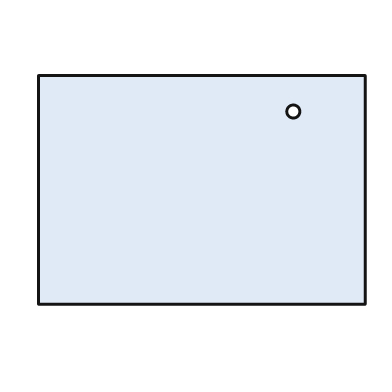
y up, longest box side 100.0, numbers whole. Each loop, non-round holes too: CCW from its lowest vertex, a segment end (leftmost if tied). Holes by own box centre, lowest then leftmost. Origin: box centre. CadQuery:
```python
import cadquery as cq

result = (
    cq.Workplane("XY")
    .moveTo(-50.0, -35.0)
    .lineTo(50.0, -35.0)
    .lineTo(50.0, 35.0)
    .lineTo(-50.0, 35.0)
    .close()
    .moveTo(28.0, 24.0)
    .circle(2.0)
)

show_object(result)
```